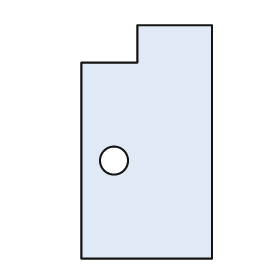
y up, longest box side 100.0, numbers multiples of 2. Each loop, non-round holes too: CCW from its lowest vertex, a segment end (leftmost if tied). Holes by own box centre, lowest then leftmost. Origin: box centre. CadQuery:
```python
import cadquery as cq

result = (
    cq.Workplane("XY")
    .moveTo(-28.0, -50.0)
    .lineTo(28.0, -50.0)
    .lineTo(28.0, 50.0)
    .lineTo(-4.0, 50.0)
    .lineTo(-4.0, 34.0)
    .lineTo(-28.0, 34.0)
    .close()
    .moveTo(-14.0, -8.0)
    .circle(6.0)
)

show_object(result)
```